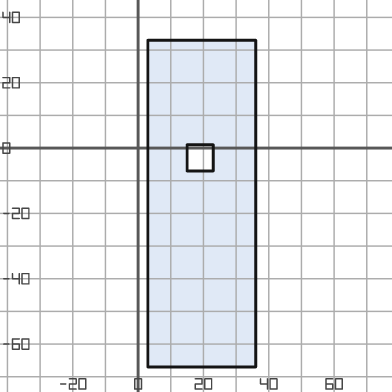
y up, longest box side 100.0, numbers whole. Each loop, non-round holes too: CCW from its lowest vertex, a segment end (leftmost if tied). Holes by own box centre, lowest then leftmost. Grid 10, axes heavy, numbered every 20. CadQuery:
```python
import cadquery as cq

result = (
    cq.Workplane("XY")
    .moveTo(3.0, -67.0)
    .lineTo(36.0, -67.0)
    .lineTo(36.0, 33.0)
    .lineTo(3.0, 33.0)
    .close()
    .moveTo(15.0, -7.0)
    .lineTo(23.0, -7.0)
    .lineTo(23.0, 1.0)
    .lineTo(15.0, 1.0)
    .close()
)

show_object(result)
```